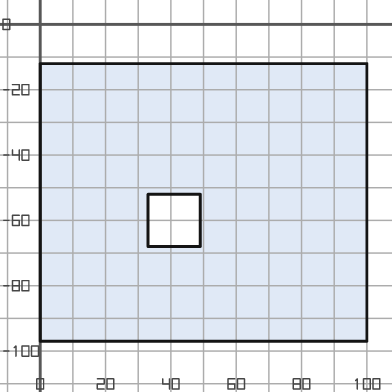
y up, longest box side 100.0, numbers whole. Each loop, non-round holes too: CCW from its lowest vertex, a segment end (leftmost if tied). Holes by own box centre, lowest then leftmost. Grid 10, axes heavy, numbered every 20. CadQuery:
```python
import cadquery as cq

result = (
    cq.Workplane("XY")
    .moveTo(0.0, -97.0)
    .lineTo(100.0, -97.0)
    .lineTo(100.0, -12.0)
    .lineTo(0.0, -12.0)
    .close()
    .moveTo(33.0, -68.0)
    .lineTo(49.0, -68.0)
    .lineTo(49.0, -52.0)
    .lineTo(33.0, -52.0)
    .close()
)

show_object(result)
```